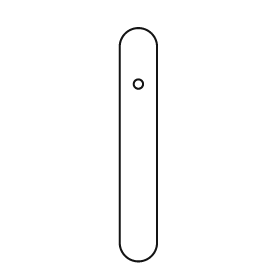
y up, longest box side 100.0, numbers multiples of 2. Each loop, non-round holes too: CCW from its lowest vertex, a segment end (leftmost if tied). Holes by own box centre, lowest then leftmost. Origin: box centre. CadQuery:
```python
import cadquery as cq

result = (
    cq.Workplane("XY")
    .moveTo(-8.0, -42.0)
    .threePointArc((0.0, -50.0), (8.0, -42.0))
    .lineTo(8.0, 42.0)
    .threePointArc((0.0, 50.0), (-8.0, 42.0))
    .close()
    .moveTo(0.0, 26.0)
    .circle(2.0)
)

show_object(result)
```